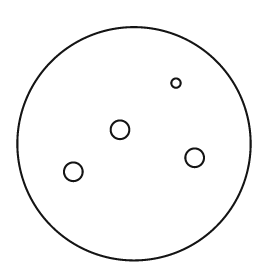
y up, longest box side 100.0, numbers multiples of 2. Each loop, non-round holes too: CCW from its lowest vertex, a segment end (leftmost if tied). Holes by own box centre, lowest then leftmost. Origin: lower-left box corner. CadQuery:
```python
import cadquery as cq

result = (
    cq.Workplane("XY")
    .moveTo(50.0, 50.0)
    .circle(50.0)
    .moveTo(24.0, 38.0)
    .circle(4.0)
    .moveTo(76.0, 44.0)
    .circle(4.0)
    .moveTo(44.0, 56.0)
    .circle(4.0)
    .moveTo(68.0, 76.0)
    .circle(2.0)
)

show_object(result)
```